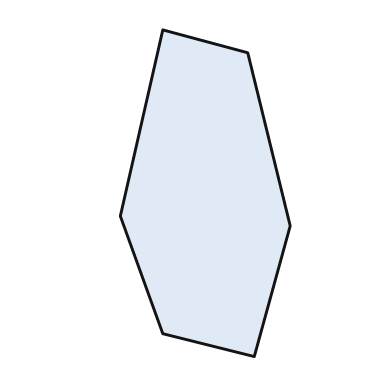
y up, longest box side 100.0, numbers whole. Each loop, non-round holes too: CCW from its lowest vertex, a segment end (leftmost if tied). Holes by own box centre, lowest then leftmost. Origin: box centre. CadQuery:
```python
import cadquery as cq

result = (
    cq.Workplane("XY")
    .moveTo(15.0, -50.0)
    .lineTo(26.0, -10.0)
    .lineTo(13.0, 43.0)
    .lineTo(-13.0, 50.0)
    .lineTo(-26.0, -7.0)
    .lineTo(-13.0, -43.0)
    .close()
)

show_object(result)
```